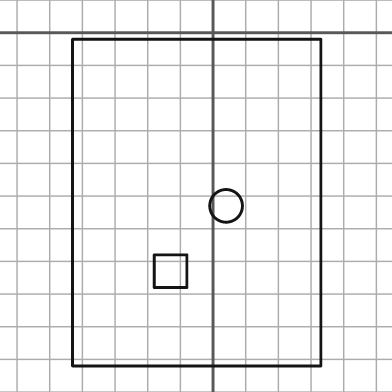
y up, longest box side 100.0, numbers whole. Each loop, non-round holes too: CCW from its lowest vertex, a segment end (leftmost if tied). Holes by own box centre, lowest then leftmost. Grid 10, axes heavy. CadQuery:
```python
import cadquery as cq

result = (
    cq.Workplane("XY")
    .moveTo(-43.0, -102.0)
    .lineTo(33.0, -102.0)
    .lineTo(33.0, -2.0)
    .lineTo(-43.0, -2.0)
    .close()
    .moveTo(-18.0, -78.0)
    .lineTo(-8.0, -78.0)
    .lineTo(-8.0, -68.0)
    .lineTo(-18.0, -68.0)
    .close()
    .moveTo(4.0, -53.0)
    .circle(5.0)
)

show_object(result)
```